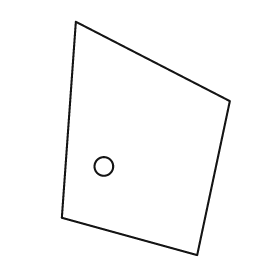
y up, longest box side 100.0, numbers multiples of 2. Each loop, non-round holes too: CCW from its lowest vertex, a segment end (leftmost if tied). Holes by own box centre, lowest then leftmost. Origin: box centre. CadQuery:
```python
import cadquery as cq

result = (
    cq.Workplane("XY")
    .moveTo(22.0, -50.0)
    .lineTo(36.0, 16.0)
    .lineTo(-30.0, 50.0)
    .lineTo(-36.0, -34.0)
    .close()
    .moveTo(-18.0, -12.0)
    .circle(4.0)
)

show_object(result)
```